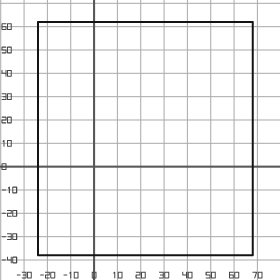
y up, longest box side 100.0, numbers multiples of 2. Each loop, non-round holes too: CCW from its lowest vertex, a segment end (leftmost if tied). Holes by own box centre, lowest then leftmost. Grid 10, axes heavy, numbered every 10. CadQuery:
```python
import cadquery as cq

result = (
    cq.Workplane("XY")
    .moveTo(-24.0, -38.0)
    .lineTo(68.0, -38.0)
    .lineTo(68.0, 62.0)
    .lineTo(-24.0, 62.0)
    .close()
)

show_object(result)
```